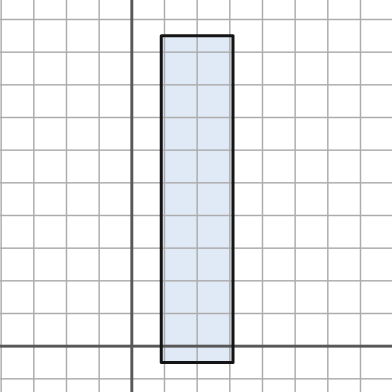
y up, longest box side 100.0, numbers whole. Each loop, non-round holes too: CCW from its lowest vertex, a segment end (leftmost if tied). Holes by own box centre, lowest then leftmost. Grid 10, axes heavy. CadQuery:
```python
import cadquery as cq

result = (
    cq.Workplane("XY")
    .moveTo(9.0, -5.0)
    .lineTo(31.0, -5.0)
    .lineTo(31.0, 95.0)
    .lineTo(9.0, 95.0)
    .close()
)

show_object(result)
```